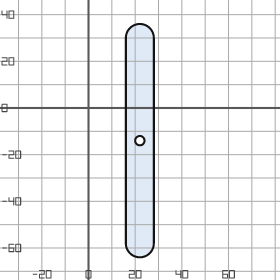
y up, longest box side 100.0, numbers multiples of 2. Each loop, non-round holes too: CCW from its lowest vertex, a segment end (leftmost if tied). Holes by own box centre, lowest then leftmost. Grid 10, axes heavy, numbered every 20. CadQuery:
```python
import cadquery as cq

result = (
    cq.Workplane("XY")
    .moveTo(16.0, -58.0)
    .threePointArc((22.0, -64.0), (28.0, -58.0))
    .lineTo(28.0, 30.0)
    .threePointArc((22.0, 36.0), (16.0, 30.0))
    .close()
    .moveTo(22.0, -14.0)
    .circle(2.0)
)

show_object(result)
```